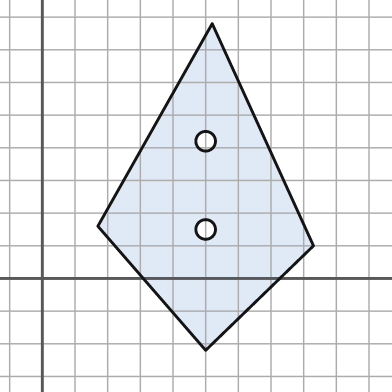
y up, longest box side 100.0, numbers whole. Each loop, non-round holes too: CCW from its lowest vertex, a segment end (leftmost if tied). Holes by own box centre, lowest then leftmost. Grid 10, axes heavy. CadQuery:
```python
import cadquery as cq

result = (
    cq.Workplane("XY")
    .moveTo(50.0, -22.0)
    .lineTo(83.0, 10.0)
    .lineTo(52.0, 78.0)
    .lineTo(17.0, 16.0)
    .close()
    .moveTo(50.0, 15.0)
    .circle(3.0)
    .moveTo(50.0, 42.0)
    .circle(3.0)
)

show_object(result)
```